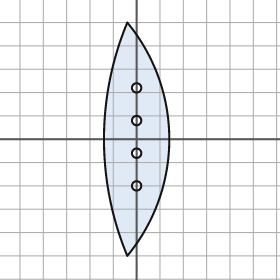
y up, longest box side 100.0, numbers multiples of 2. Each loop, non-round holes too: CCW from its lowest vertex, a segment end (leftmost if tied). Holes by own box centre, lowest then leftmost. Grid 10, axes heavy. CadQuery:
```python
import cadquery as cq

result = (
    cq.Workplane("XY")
    .moveTo(-4.0, -50.0)
    .threePointArc((14.0, 0.0), (-4.0, 50.0))
    .threePointArc((-14.0, 0.0), (-4.0, -50.0))
    .close()
    .moveTo(0.0, -20.0)
    .circle(2.0)
    .moveTo(0.0, -6.0)
    .circle(2.0)
    .moveTo(0.0, 8.0)
    .circle(2.0)
    .moveTo(0.0, 22.0)
    .circle(2.0)
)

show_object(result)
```